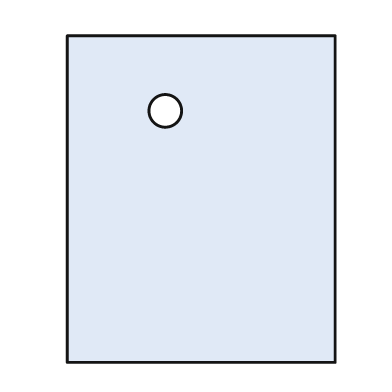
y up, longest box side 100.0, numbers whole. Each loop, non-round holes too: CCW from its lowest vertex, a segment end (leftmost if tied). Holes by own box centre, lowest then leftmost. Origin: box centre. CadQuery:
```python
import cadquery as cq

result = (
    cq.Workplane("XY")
    .moveTo(-41.0, -50.0)
    .lineTo(41.0, -50.0)
    .lineTo(41.0, 50.0)
    .lineTo(-41.0, 50.0)
    .close()
    .moveTo(-11.0, 27.0)
    .circle(5.0)
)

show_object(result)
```